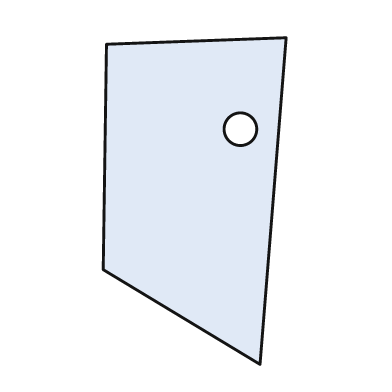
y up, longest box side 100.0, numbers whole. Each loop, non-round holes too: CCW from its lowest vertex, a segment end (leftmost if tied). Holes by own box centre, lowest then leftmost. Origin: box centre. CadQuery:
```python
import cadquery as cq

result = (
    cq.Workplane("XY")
    .moveTo(20.0, -50.0)
    .lineTo(28.0, 50.0)
    .lineTo(-27.0, 48.0)
    .lineTo(-28.0, -21.0)
    .close()
    .moveTo(14.0, 22.0)
    .circle(5.0)
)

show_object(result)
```